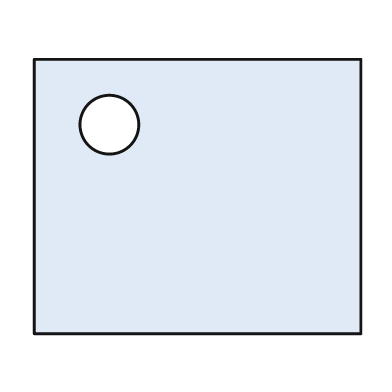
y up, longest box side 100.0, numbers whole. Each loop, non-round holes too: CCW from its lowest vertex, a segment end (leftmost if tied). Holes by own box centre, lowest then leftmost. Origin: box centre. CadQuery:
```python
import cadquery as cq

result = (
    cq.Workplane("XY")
    .moveTo(-50.0, -42.0)
    .lineTo(50.0, -42.0)
    .lineTo(50.0, 42.0)
    .lineTo(-50.0, 42.0)
    .close()
    .moveTo(-27.0, 22.0)
    .circle(9.0)
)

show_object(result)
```